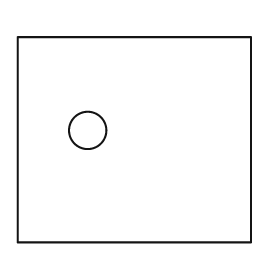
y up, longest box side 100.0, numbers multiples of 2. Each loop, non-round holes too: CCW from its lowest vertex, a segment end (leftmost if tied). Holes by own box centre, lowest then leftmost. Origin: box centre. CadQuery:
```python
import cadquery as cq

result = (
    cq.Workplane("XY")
    .moveTo(-50.0, -44.0)
    .lineTo(50.0, -44.0)
    .lineTo(50.0, 44.0)
    .lineTo(-50.0, 44.0)
    .close()
    .moveTo(-20.0, 4.0)
    .circle(8.0)
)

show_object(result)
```